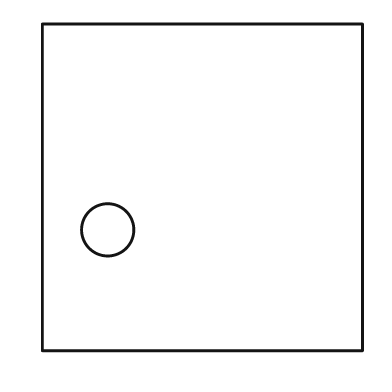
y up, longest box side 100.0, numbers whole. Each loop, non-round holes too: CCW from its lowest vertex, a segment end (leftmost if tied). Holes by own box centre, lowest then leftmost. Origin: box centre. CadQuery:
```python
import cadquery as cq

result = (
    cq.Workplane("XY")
    .moveTo(-49.0, -50.0)
    .lineTo(49.0, -50.0)
    .lineTo(49.0, 50.0)
    .lineTo(-49.0, 50.0)
    .close()
    .moveTo(-29.0, -13.0)
    .circle(8.0)
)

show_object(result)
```